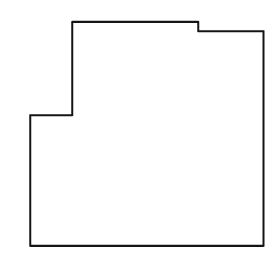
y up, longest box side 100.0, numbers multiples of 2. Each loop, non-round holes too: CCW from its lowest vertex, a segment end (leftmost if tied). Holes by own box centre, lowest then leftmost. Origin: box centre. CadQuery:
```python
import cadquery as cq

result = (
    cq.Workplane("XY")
    .moveTo(-50.0, -48.0)
    .lineTo(50.0, -48.0)
    .lineTo(50.0, 44.0)
    .lineTo(22.0, 44.0)
    .lineTo(22.0, 48.0)
    .lineTo(-32.0, 48.0)
    .lineTo(-32.0, 8.0)
    .lineTo(-50.0, 8.0)
    .close()
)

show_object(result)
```